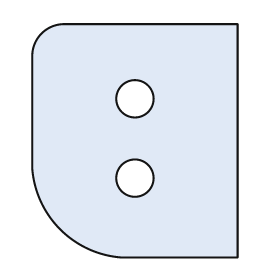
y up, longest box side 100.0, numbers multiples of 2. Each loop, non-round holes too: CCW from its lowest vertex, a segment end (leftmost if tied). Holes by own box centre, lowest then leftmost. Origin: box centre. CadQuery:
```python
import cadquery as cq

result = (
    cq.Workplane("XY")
    .moveTo(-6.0, -50.0)
    .lineTo(44.0, -50.0)
    .lineTo(44.0, 50.0)
    .lineTo(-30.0, 50.0)
    .threePointArc((-40.0, 46.0), (-44.0, 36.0))
    .lineTo(-44.0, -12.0)
    .threePointArc((-32.0, -38.0), (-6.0, -50.0))
    .close()
    .moveTo(0.0, -16.0)
    .circle(8.0)
    .moveTo(0.0, 18.0)
    .circle(8.0)
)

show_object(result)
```